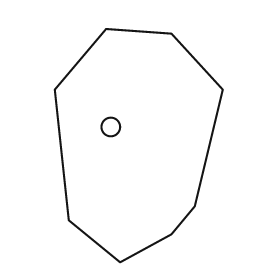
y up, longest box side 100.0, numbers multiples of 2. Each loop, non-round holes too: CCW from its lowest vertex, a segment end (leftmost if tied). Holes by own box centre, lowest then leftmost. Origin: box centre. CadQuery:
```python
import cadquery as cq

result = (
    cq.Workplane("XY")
    .moveTo(-8.0, -50.0)
    .lineTo(14.0, -38.0)
    .lineTo(24.0, -26.0)
    .lineTo(36.0, 24.0)
    .lineTo(14.0, 48.0)
    .lineTo(-14.0, 50.0)
    .lineTo(-36.0, 24.0)
    .lineTo(-30.0, -32.0)
    .close()
    .moveTo(-12.0, 8.0)
    .circle(4.0)
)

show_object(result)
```